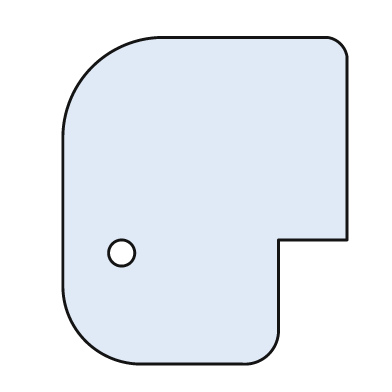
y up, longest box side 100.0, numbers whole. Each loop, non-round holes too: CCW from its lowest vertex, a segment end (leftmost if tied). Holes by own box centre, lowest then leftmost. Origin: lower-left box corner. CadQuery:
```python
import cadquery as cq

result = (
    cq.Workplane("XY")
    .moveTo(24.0, 0.0)
    .lineTo(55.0, 0.0)
    .threePointArc((63.0, 3.0), (66.0, 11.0))
    .lineTo(66.0, 38.0)
    .lineTo(87.0, 38.0)
    .lineTo(87.0, 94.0)
    .threePointArc((85.0, 98.0), (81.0, 100.0))
    .lineTo(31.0, 100.0)
    .threePointArc((9.0, 91.0), (0.0, 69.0))
    .lineTo(0.0, 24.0)
    .threePointArc((7.0, 7.0), (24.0, 0.0))
    .close()
    .moveTo(18.0, 34.0)
    .circle(4.0)
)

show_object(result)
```